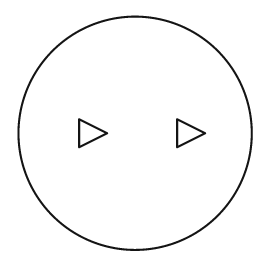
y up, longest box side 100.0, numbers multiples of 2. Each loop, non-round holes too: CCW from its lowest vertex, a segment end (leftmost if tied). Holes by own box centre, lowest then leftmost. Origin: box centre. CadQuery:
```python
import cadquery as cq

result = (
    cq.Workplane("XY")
    .moveTo(0.0, 0.0)
    .circle(50.0)
    .moveTo(-24.0, -6.0)
    .lineTo(-12.0, 0.0)
    .lineTo(-24.0, 6.0)
    .close()
    .moveTo(18.0, -6.0)
    .lineTo(30.0, 0.0)
    .lineTo(18.0, 6.0)
    .close()
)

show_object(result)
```